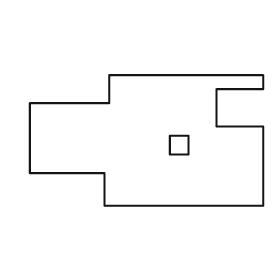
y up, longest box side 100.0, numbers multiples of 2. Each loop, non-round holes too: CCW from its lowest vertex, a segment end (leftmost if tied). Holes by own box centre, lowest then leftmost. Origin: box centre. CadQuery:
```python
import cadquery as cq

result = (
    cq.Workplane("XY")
    .moveTo(-18.0, -28.0)
    .lineTo(50.0, -28.0)
    .lineTo(50.0, 6.0)
    .lineTo(30.0, 6.0)
    .lineTo(30.0, 22.0)
    .lineTo(50.0, 22.0)
    .lineTo(50.0, 28.0)
    .lineTo(-16.0, 28.0)
    .lineTo(-16.0, 16.0)
    .lineTo(-50.0, 16.0)
    .lineTo(-50.0, -14.0)
    .lineTo(-18.0, -14.0)
    .close()
    .moveTo(10.0, -6.0)
    .lineTo(18.0, -6.0)
    .lineTo(18.0, 2.0)
    .lineTo(10.0, 2.0)
    .close()
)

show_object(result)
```